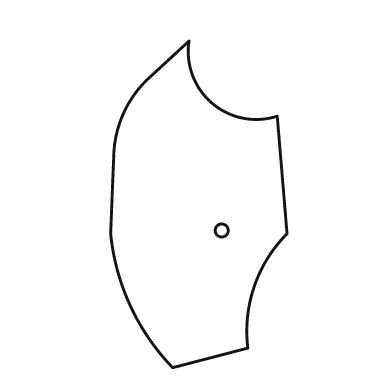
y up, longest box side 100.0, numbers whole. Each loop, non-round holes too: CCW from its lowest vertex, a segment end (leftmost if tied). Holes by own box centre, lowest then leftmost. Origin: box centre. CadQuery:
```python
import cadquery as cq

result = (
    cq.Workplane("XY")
    .moveTo(-8.0, -50.0)
    .lineTo(15.0, -44.0)
    .threePointArc((17.0, -25.0), (27.0, -9.0))
    .lineTo(24.0, 27.0)
    .threePointArc((4.0, 31.0), (-3.0, 50.0))
    .lineTo(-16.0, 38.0)
    .threePointArc((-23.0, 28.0), (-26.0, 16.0))
    .lineTo(-27.0, -9.0)
    .threePointArc((-21.0, -31.0), (-8.0, -50.0))
    .close()
    .moveTo(7.0, -8.0)
    .circle(2.0)
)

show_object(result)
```